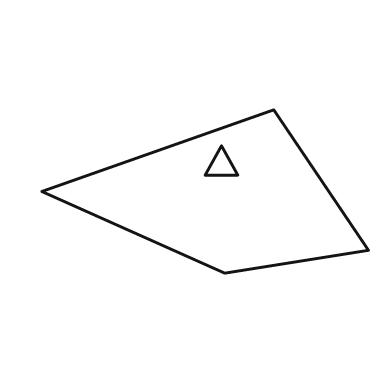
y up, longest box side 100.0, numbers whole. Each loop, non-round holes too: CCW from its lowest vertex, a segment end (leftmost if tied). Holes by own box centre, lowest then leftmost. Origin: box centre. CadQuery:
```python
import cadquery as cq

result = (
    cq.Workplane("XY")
    .moveTo(6.0, -25.0)
    .lineTo(50.0, -18.0)
    .lineTo(21.0, 25.0)
    .lineTo(-50.0, 0.0)
    .close()
    .moveTo(0.0, 5.0)
    .lineTo(10.0, 5.0)
    .lineTo(5.0, 14.0)
    .close()
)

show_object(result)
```